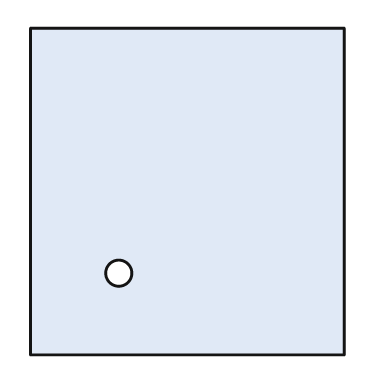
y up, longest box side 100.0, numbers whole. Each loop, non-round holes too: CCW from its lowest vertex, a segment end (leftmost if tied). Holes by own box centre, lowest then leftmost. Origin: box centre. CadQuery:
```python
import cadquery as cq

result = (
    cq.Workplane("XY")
    .moveTo(-48.0, -50.0)
    .lineTo(48.0, -50.0)
    .lineTo(48.0, 50.0)
    .lineTo(-48.0, 50.0)
    .close()
    .moveTo(-21.0, -25.0)
    .circle(4.0)
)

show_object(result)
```